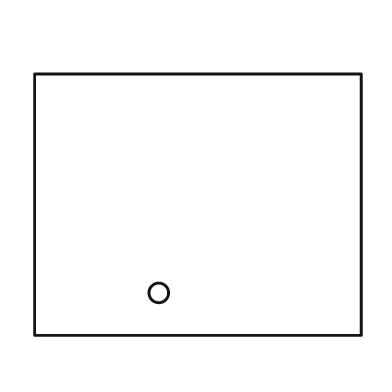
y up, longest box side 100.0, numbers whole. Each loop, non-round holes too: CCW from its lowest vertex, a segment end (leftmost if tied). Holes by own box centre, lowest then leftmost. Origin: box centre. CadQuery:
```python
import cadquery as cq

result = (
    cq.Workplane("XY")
    .moveTo(-50.0, -40.0)
    .lineTo(50.0, -40.0)
    .lineTo(50.0, 40.0)
    .lineTo(-50.0, 40.0)
    .close()
    .moveTo(-12.0, -27.0)
    .circle(3.0)
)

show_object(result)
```